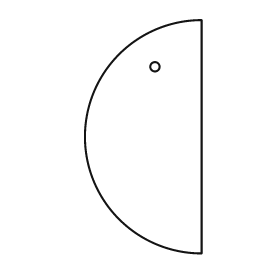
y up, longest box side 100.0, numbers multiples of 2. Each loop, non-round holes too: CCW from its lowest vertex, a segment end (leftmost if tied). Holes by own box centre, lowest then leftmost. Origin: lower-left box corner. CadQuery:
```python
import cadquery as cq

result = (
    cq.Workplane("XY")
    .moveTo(50.0, 0.0)
    .lineTo(50.0, 100.0)
    .threePointArc((0.0, 50.0), (50.0, 0.0))
    .close()
    .moveTo(30.0, 80.0)
    .circle(2.0)
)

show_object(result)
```